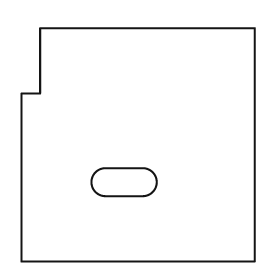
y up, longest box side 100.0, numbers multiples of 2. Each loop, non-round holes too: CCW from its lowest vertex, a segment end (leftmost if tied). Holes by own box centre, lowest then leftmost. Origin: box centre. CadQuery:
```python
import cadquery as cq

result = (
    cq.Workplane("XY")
    .moveTo(-50.0, -50.0)
    .lineTo(50.0, -50.0)
    .lineTo(50.0, 50.0)
    .lineTo(-42.0, 50.0)
    .lineTo(-42.0, 22.0)
    .lineTo(-50.0, 22.0)
    .close()
    .moveTo(-14.0, -22.0)
    .lineTo(2.0, -22.0)
    .threePointArc((8.0, -16.0), (2.0, -10.0))
    .lineTo(-14.0, -10.0)
    .threePointArc((-20.0, -16.0), (-14.0, -22.0))
    .close()
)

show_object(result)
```